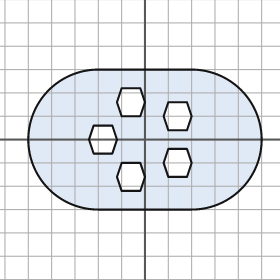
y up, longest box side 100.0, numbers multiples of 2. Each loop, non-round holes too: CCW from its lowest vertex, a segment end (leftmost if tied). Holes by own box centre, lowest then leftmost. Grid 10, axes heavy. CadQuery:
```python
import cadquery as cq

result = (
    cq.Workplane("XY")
    .moveTo(-20.0, -30.0)
    .lineTo(20.0, -30.0)
    .threePointArc((50.0, 0.0), (20.0, 30.0))
    .lineTo(-20.0, 30.0)
    .threePointArc((-50.0, 0.0), (-20.0, -30.0))
    .close()
    .moveTo(-10.0, -22.0)
    .lineTo(-2.0, -22.0)
    .lineTo(0.0, -16.0)
    .lineTo(-2.0, -10.0)
    .lineTo(-10.0, -10.0)
    .lineTo(-12.0, -16.0)
    .close()
    .moveTo(10.0, -16.0)
    .lineTo(18.0, -16.0)
    .lineTo(20.0, -10.0)
    .lineTo(18.0, -4.0)
    .lineTo(10.0, -4.0)
    .lineTo(8.0, -10.0)
    .close()
    .moveTo(-22.0, -6.0)
    .lineTo(-14.0, -6.0)
    .lineTo(-12.0, 0.0)
    .lineTo(-14.0, 6.0)
    .lineTo(-22.0, 6.0)
    .lineTo(-24.0, 0.0)
    .close()
    .moveTo(10.0, 4.0)
    .lineTo(18.0, 4.0)
    .lineTo(20.0, 10.0)
    .lineTo(18.0, 16.0)
    .lineTo(10.0, 16.0)
    .lineTo(8.0, 10.0)
    .close()
    .moveTo(-10.0, 10.0)
    .lineTo(-2.0, 10.0)
    .lineTo(0.0, 16.0)
    .lineTo(-2.0, 22.0)
    .lineTo(-10.0, 22.0)
    .lineTo(-12.0, 16.0)
    .close()
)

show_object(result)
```